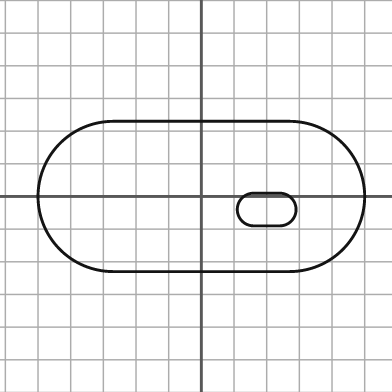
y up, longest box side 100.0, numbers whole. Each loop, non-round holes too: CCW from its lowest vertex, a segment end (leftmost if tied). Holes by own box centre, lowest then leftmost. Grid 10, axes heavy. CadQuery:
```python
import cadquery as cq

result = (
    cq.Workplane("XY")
    .moveTo(-27.0, -23.0)
    .lineTo(27.0, -23.0)
    .threePointArc((50.0, 0.0), (27.0, 23.0))
    .lineTo(-27.0, 23.0)
    .threePointArc((-50.0, 0.0), (-27.0, -23.0))
    .close()
    .moveTo(16.0, -9.0)
    .lineTo(24.0, -9.0)
    .threePointArc((29.0, -4.0), (24.0, 1.0))
    .lineTo(16.0, 1.0)
    .threePointArc((11.0, -4.0), (16.0, -9.0))
    .close()
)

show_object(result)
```